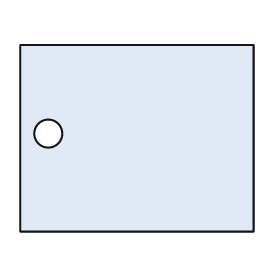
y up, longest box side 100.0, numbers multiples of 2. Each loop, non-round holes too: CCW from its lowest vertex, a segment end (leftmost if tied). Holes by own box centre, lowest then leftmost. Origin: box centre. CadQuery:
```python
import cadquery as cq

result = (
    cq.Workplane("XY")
    .moveTo(-50.0, -40.0)
    .lineTo(50.0, -40.0)
    .lineTo(50.0, 40.0)
    .lineTo(-50.0, 40.0)
    .close()
    .moveTo(-38.0, 2.0)
    .circle(6.0)
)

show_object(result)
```